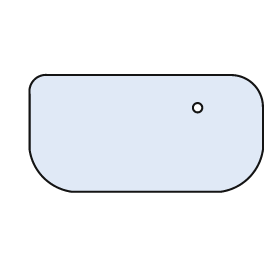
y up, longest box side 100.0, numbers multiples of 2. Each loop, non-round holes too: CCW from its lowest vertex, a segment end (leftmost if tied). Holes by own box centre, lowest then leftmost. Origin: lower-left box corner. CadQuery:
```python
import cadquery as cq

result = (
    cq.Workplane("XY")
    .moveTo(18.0, 0.0)
    .lineTo(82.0, 0.0)
    .threePointArc((94.0, 6.0), (100.0, 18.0))
    .lineTo(100.0, 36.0)
    .threePointArc((96.0, 46.0), (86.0, 50.0))
    .lineTo(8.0, 50.0)
    .threePointArc((2.0, 48.0), (0.0, 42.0))
    .lineTo(0.0, 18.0)
    .threePointArc((6.0, 6.0), (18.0, 0.0))
    .close()
    .moveTo(72.0, 36.0)
    .circle(2.0)
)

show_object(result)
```